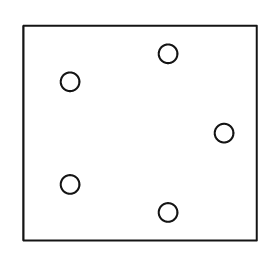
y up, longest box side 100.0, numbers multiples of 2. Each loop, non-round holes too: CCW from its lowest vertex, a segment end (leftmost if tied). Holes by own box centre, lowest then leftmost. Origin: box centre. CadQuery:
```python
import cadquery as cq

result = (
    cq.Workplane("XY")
    .moveTo(-50.0, -46.0)
    .lineTo(50.0, -46.0)
    .lineTo(50.0, 46.0)
    .lineTo(-50.0, 46.0)
    .close()
    .moveTo(12.0, -34.0)
    .circle(4.0)
    .moveTo(-30.0, -22.0)
    .circle(4.0)
    .moveTo(36.0, 0.0)
    .circle(4.0)
    .moveTo(-30.0, 22.0)
    .circle(4.0)
    .moveTo(12.0, 34.0)
    .circle(4.0)
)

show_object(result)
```